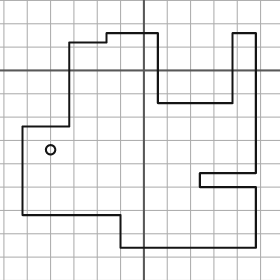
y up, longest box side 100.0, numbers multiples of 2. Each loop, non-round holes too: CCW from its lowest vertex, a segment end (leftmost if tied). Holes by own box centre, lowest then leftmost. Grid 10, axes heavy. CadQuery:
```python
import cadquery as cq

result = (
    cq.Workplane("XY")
    .moveTo(-10.0, -76.0)
    .lineTo(48.0, -76.0)
    .lineTo(48.0, -50.0)
    .lineTo(24.0, -50.0)
    .lineTo(24.0, -44.0)
    .lineTo(48.0, -44.0)
    .lineTo(48.0, 16.0)
    .lineTo(38.0, 16.0)
    .lineTo(38.0, -14.0)
    .lineTo(6.0, -14.0)
    .lineTo(6.0, 16.0)
    .lineTo(-16.0, 16.0)
    .lineTo(-16.0, 12.0)
    .lineTo(-32.0, 12.0)
    .lineTo(-32.0, -24.0)
    .lineTo(-52.0, -24.0)
    .lineTo(-52.0, -62.0)
    .lineTo(-10.0, -62.0)
    .close()
    .moveTo(-40.0, -34.0)
    .circle(2.0)
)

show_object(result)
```